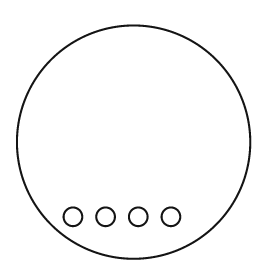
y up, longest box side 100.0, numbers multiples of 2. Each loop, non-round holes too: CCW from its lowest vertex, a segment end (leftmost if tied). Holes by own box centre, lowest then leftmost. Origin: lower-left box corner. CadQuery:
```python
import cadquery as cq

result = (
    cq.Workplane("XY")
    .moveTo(50.0, 50.0)
    .circle(50.0)
    .moveTo(24.0, 18.0)
    .circle(4.0)
    .moveTo(38.0, 18.0)
    .circle(4.0)
    .moveTo(52.0, 18.0)
    .circle(4.0)
    .moveTo(66.0, 18.0)
    .circle(4.0)
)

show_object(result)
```